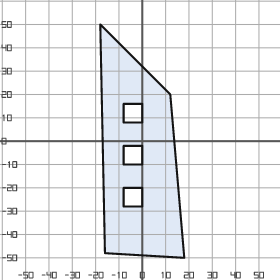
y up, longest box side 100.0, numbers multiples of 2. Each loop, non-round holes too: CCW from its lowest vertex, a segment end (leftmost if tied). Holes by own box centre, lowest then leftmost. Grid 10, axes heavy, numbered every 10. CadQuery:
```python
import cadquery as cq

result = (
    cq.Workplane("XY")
    .moveTo(18.0, -50.0)
    .lineTo(12.0, 20.0)
    .lineTo(-18.0, 50.0)
    .lineTo(-16.0, -48.0)
    .close()
    .moveTo(-8.0, -28.0)
    .lineTo(0.0, -28.0)
    .lineTo(0.0, -20.0)
    .lineTo(-8.0, -20.0)
    .close()
    .moveTo(-8.0, -10.0)
    .lineTo(0.0, -10.0)
    .lineTo(0.0, -2.0)
    .lineTo(-8.0, -2.0)
    .close()
    .moveTo(-8.0, 8.0)
    .lineTo(0.0, 8.0)
    .lineTo(0.0, 16.0)
    .lineTo(-8.0, 16.0)
    .close()
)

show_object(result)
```